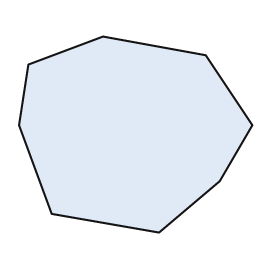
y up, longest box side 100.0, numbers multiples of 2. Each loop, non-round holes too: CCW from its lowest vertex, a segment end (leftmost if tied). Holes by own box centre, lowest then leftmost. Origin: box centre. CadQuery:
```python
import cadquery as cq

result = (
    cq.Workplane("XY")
    .moveTo(10.0, -42.0)
    .lineTo(36.0, -20.0)
    .lineTo(50.0, 4.0)
    .lineTo(30.0, 34.0)
    .lineTo(-14.0, 42.0)
    .lineTo(-46.0, 30.0)
    .lineTo(-50.0, 4.0)
    .lineTo(-36.0, -34.0)
    .close()
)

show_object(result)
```